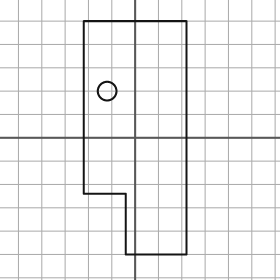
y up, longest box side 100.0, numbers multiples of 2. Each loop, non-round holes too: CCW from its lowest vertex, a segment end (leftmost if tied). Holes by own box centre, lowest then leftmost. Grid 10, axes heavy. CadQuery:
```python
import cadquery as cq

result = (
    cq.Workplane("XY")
    .moveTo(-4.0, -50.0)
    .lineTo(22.0, -50.0)
    .lineTo(22.0, 50.0)
    .lineTo(-22.0, 50.0)
    .lineTo(-22.0, -24.0)
    .lineTo(-4.0, -24.0)
    .close()
    .moveTo(-12.0, 20.0)
    .circle(4.0)
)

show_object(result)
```